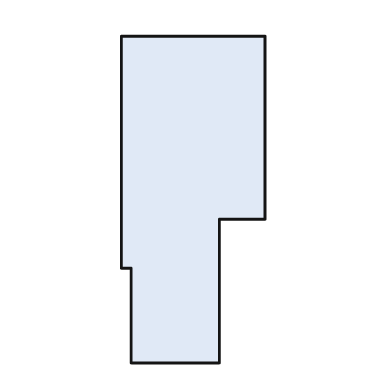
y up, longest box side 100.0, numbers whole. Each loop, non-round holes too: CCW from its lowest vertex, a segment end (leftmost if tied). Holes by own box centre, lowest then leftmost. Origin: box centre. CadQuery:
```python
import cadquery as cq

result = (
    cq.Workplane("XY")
    .moveTo(-19.0, -50.0)
    .lineTo(8.0, -50.0)
    .lineTo(8.0, -6.0)
    .lineTo(22.0, -6.0)
    .lineTo(22.0, 50.0)
    .lineTo(-22.0, 50.0)
    .lineTo(-22.0, -21.0)
    .lineTo(-19.0, -21.0)
    .close()
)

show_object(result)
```